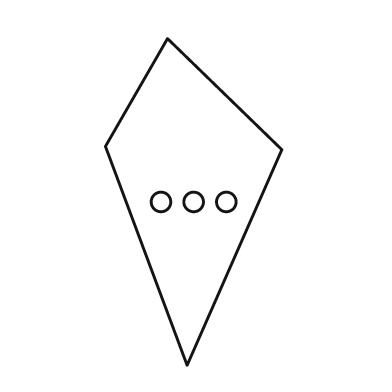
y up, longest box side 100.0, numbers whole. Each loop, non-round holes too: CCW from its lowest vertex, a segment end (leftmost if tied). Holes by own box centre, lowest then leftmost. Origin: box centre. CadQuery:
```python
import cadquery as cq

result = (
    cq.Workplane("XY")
    .moveTo(-2.0, -50.0)
    .lineTo(27.0, 16.0)
    .lineTo(-8.0, 50.0)
    .lineTo(-27.0, 17.0)
    .close()
    .moveTo(-10.0, 0.0)
    .circle(3.0)
    .moveTo(0.0, 0.0)
    .circle(3.0)
    .moveTo(10.0, 0.0)
    .circle(3.0)
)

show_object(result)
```